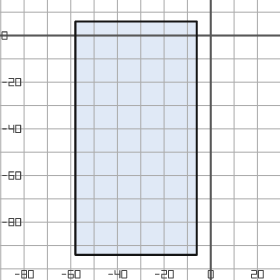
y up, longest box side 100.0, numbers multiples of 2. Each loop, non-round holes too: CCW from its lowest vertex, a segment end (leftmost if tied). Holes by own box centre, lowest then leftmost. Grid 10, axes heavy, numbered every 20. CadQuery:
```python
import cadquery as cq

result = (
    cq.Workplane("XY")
    .moveTo(-58.0, -94.0)
    .lineTo(-6.0, -94.0)
    .lineTo(-6.0, 6.0)
    .lineTo(-58.0, 6.0)
    .close()
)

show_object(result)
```